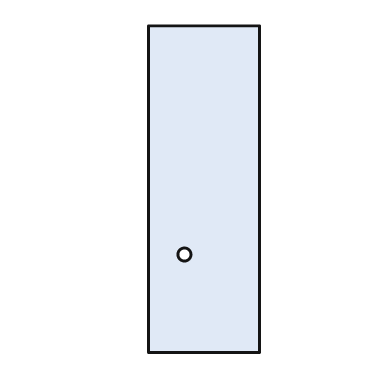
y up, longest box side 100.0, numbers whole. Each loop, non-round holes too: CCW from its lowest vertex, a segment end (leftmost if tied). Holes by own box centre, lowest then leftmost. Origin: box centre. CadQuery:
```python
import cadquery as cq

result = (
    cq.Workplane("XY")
    .moveTo(-17.0, -50.0)
    .lineTo(17.0, -50.0)
    .lineTo(17.0, 50.0)
    .lineTo(-17.0, 50.0)
    .close()
    .moveTo(-6.0, -20.0)
    .circle(2.0)
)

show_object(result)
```